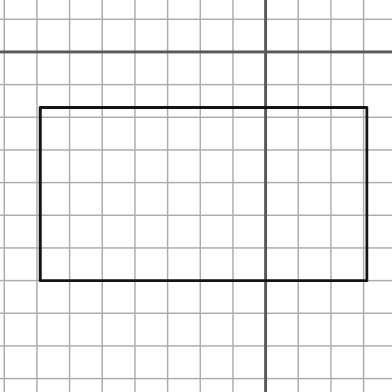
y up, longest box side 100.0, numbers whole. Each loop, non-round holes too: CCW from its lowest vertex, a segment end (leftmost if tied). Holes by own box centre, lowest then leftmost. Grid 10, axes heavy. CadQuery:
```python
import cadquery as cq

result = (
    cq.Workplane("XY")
    .moveTo(-69.0, -70.0)
    .lineTo(31.0, -70.0)
    .lineTo(31.0, -17.0)
    .lineTo(-69.0, -17.0)
    .close()
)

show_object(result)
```